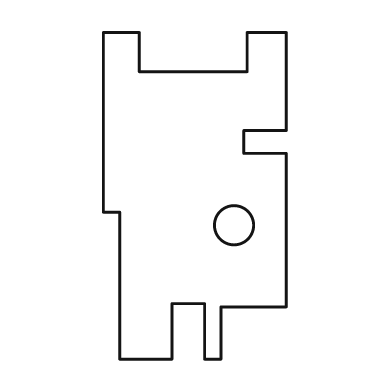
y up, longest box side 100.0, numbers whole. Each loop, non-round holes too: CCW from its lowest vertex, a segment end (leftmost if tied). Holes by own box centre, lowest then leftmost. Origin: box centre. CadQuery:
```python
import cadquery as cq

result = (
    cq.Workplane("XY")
    .moveTo(-23.0, -50.0)
    .lineTo(-7.0, -50.0)
    .lineTo(-7.0, -33.0)
    .lineTo(3.0, -33.0)
    .lineTo(3.0, -50.0)
    .lineTo(8.0, -50.0)
    .lineTo(8.0, -34.0)
    .lineTo(28.0, -34.0)
    .lineTo(28.0, 13.0)
    .lineTo(15.0, 13.0)
    .lineTo(15.0, 20.0)
    .lineTo(28.0, 20.0)
    .lineTo(28.0, 50.0)
    .lineTo(16.0, 50.0)
    .lineTo(16.0, 38.0)
    .lineTo(-17.0, 38.0)
    .lineTo(-17.0, 50.0)
    .lineTo(-28.0, 50.0)
    .lineTo(-28.0, -5.0)
    .lineTo(-23.0, -5.0)
    .close()
    .moveTo(12.0, -9.0)
    .circle(6.0)
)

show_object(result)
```